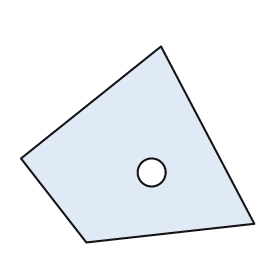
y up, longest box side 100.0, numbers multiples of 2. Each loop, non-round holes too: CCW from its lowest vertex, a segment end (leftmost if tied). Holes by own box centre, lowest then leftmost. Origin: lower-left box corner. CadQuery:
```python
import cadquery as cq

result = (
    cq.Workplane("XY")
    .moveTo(28.0, 0.0)
    .lineTo(100.0, 8.0)
    .lineTo(60.0, 84.0)
    .lineTo(0.0, 36.0)
    .close()
    .moveTo(56.0, 30.0)
    .circle(6.0)
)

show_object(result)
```